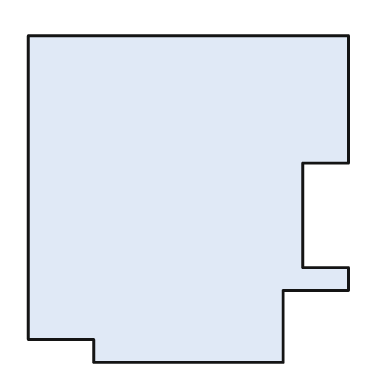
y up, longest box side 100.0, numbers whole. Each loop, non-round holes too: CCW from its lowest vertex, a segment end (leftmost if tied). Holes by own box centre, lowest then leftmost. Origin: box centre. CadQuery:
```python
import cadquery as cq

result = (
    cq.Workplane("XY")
    .moveTo(-29.0, -50.0)
    .lineTo(29.0, -50.0)
    .lineTo(29.0, -28.0)
    .lineTo(49.0, -28.0)
    .lineTo(49.0, -21.0)
    .lineTo(35.0, -21.0)
    .lineTo(35.0, 11.0)
    .lineTo(49.0, 11.0)
    .lineTo(49.0, 50.0)
    .lineTo(-49.0, 50.0)
    .lineTo(-49.0, -43.0)
    .lineTo(-29.0, -43.0)
    .close()
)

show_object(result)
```